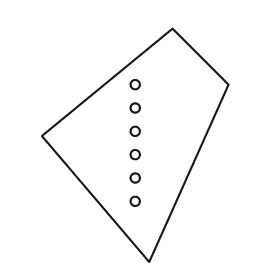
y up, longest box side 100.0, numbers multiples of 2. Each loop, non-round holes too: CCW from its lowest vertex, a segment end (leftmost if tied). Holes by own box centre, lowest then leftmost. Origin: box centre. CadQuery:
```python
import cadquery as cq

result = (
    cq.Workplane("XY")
    .moveTo(6.0, -50.0)
    .lineTo(40.0, 26.0)
    .lineTo(16.0, 50.0)
    .lineTo(-40.0, 4.0)
    .close()
    .moveTo(0.0, -24.0)
    .circle(2.0)
    .moveTo(0.0, -14.0)
    .circle(2.0)
    .moveTo(0.0, -4.0)
    .circle(2.0)
    .moveTo(0.0, 6.0)
    .circle(2.0)
    .moveTo(0.0, 16.0)
    .circle(2.0)
    .moveTo(0.0, 26.0)
    .circle(2.0)
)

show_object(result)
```